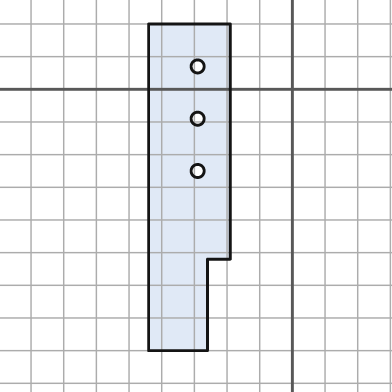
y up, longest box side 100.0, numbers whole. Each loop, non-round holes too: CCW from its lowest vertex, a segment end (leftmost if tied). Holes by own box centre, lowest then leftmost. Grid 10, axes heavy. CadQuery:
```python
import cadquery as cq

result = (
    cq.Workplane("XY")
    .moveTo(-44.0, -80.0)
    .lineTo(-26.0, -80.0)
    .lineTo(-26.0, -52.0)
    .lineTo(-19.0, -52.0)
    .lineTo(-19.0, 20.0)
    .lineTo(-44.0, 20.0)
    .close()
    .moveTo(-29.0, -25.0)
    .circle(2.0)
    .moveTo(-29.0, -9.0)
    .circle(2.0)
    .moveTo(-29.0, 7.0)
    .circle(2.0)
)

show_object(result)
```